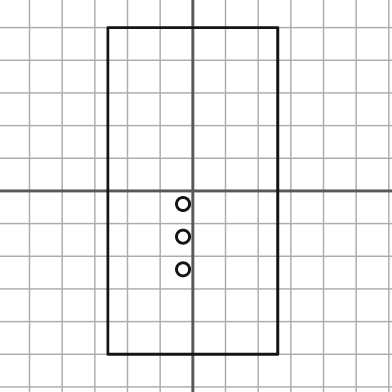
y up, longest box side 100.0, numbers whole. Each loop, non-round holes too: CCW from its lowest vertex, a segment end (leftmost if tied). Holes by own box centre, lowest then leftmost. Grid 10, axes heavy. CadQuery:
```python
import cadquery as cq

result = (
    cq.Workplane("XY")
    .moveTo(-26.0, -50.0)
    .lineTo(26.0, -50.0)
    .lineTo(26.0, 50.0)
    .lineTo(-26.0, 50.0)
    .close()
    .moveTo(-3.0, -24.0)
    .circle(2.0)
    .moveTo(-3.0, -14.0)
    .circle(2.0)
    .moveTo(-3.0, -4.0)
    .circle(2.0)
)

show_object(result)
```